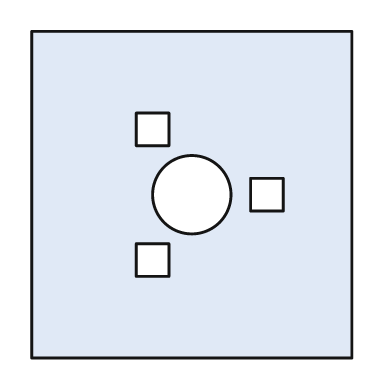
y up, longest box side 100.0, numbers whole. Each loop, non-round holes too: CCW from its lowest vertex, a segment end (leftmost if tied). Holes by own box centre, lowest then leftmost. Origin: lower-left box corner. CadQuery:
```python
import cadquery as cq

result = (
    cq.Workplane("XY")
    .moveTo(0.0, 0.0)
    .lineTo(98.0, 0.0)
    .lineTo(98.0, 100.0)
    .lineTo(0.0, 100.0)
    .close()
    .moveTo(32.0, 25.0)
    .lineTo(42.0, 25.0)
    .lineTo(42.0, 35.0)
    .lineTo(32.0, 35.0)
    .close()
    .moveTo(49.0, 50.0)
    .circle(12.0)
    .moveTo(67.0, 45.0)
    .lineTo(77.0, 45.0)
    .lineTo(77.0, 55.0)
    .lineTo(67.0, 55.0)
    .close()
    .moveTo(32.0, 65.0)
    .lineTo(42.0, 65.0)
    .lineTo(42.0, 75.0)
    .lineTo(32.0, 75.0)
    .close()
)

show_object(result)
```